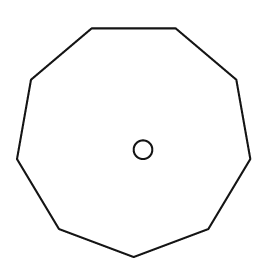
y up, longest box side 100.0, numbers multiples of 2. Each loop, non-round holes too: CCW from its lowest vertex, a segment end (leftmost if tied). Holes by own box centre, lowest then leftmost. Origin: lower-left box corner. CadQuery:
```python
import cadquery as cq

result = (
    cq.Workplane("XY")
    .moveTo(50.0, 0.0)
    .lineTo(82.0, 12.0)
    .lineTo(100.0, 42.0)
    .lineTo(94.0, 76.0)
    .lineTo(68.0, 98.0)
    .lineTo(32.0, 98.0)
    .lineTo(6.0, 76.0)
    .lineTo(0.0, 42.0)
    .lineTo(18.0, 12.0)
    .close()
    .moveTo(54.0, 46.0)
    .circle(4.0)
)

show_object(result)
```